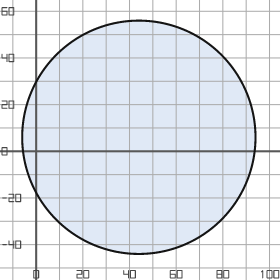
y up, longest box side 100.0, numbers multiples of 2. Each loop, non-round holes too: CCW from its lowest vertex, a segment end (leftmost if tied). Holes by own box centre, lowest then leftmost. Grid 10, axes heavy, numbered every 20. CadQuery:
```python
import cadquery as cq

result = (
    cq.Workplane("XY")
    .moveTo(44.0, 6.0)
    .circle(50.0)
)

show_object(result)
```